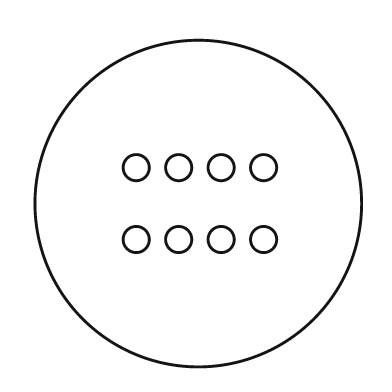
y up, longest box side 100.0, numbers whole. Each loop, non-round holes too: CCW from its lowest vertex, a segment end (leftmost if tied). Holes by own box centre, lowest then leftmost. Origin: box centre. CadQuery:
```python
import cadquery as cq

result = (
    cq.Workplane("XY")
    .moveTo(0.0, 0.0)
    .circle(50.0)
    .moveTo(-19.0, -11.0)
    .circle(4.0)
    .moveTo(-6.0, -11.0)
    .circle(4.0)
    .moveTo(7.0, -11.0)
    .circle(4.0)
    .moveTo(20.0, -11.0)
    .circle(4.0)
    .moveTo(-19.0, 11.0)
    .circle(4.0)
    .moveTo(-6.0, 11.0)
    .circle(4.0)
    .moveTo(7.0, 11.0)
    .circle(4.0)
    .moveTo(20.0, 11.0)
    .circle(4.0)
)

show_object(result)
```